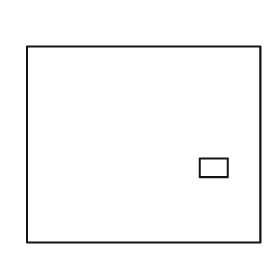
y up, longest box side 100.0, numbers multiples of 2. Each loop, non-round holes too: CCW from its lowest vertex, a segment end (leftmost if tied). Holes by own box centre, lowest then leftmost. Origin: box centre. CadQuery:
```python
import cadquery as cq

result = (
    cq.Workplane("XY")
    .moveTo(-50.0, -42.0)
    .lineTo(50.0, -42.0)
    .lineTo(50.0, 42.0)
    .lineTo(-50.0, 42.0)
    .close()
    .moveTo(24.0, -14.0)
    .lineTo(36.0, -14.0)
    .lineTo(36.0, -6.0)
    .lineTo(24.0, -6.0)
    .close()
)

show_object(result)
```